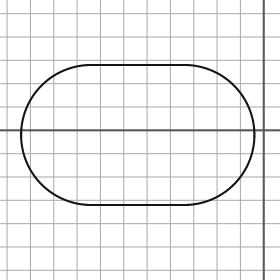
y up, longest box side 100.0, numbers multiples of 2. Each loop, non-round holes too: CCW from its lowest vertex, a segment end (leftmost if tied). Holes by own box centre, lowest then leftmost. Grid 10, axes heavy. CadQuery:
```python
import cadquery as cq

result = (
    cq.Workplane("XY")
    .moveTo(-74.0, -32.0)
    .lineTo(-34.0, -32.0)
    .threePointArc((-4.0, -2.0), (-34.0, 28.0))
    .lineTo(-74.0, 28.0)
    .threePointArc((-104.0, -2.0), (-74.0, -32.0))
    .close()
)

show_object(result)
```